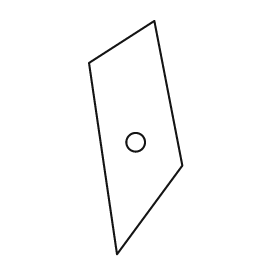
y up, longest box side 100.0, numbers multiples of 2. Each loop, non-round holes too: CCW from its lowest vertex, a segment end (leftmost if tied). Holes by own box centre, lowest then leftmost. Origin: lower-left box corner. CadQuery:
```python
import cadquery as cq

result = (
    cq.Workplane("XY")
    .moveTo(12.0, 0.0)
    .lineTo(40.0, 38.0)
    .lineTo(28.0, 100.0)
    .lineTo(0.0, 82.0)
    .close()
    .moveTo(20.0, 48.0)
    .circle(4.0)
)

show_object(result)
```